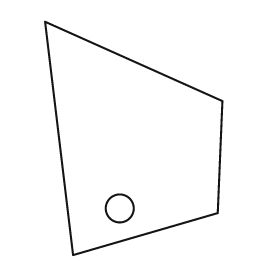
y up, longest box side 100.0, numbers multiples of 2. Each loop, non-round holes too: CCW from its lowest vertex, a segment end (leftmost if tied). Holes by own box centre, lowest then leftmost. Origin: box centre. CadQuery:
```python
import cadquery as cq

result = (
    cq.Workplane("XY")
    .moveTo(-26.0, -50.0)
    .lineTo(36.0, -32.0)
    .lineTo(38.0, 16.0)
    .lineTo(-38.0, 50.0)
    .close()
    .moveTo(-6.0, -30.0)
    .circle(6.0)
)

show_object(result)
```